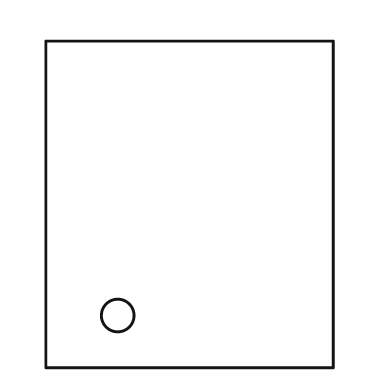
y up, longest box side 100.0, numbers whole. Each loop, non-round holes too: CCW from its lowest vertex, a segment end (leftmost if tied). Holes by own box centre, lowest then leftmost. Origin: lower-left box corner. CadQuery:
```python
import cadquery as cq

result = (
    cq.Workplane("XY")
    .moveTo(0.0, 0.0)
    .lineTo(88.0, 0.0)
    .lineTo(88.0, 100.0)
    .lineTo(0.0, 100.0)
    .close()
    .moveTo(22.0, 16.0)
    .circle(5.0)
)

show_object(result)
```